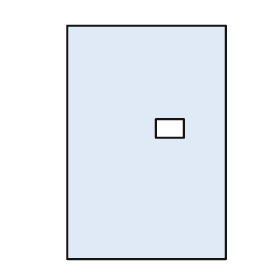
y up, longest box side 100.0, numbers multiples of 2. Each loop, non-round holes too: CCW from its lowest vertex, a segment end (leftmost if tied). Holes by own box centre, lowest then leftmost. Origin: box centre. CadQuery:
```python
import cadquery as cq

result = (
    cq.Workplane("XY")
    .moveTo(-34.0, -50.0)
    .lineTo(34.0, -50.0)
    .lineTo(34.0, 50.0)
    .lineTo(-34.0, 50.0)
    .close()
    .moveTo(4.0, 2.0)
    .lineTo(16.0, 2.0)
    .lineTo(16.0, 10.0)
    .lineTo(4.0, 10.0)
    .close()
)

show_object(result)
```